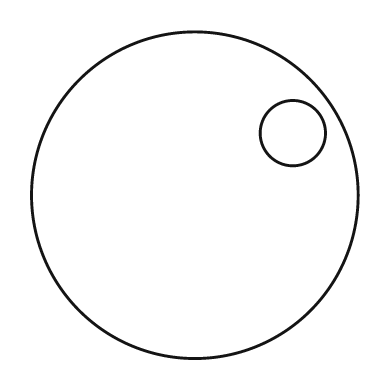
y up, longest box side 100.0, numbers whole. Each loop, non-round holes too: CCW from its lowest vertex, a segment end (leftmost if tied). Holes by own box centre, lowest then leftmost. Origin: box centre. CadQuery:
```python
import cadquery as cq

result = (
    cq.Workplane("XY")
    .moveTo(0.0, 0.0)
    .circle(50.0)
    .moveTo(30.0, 19.0)
    .circle(10.0)
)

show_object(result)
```